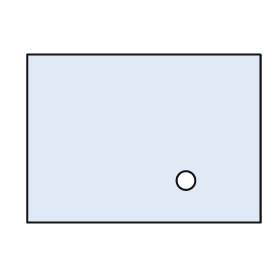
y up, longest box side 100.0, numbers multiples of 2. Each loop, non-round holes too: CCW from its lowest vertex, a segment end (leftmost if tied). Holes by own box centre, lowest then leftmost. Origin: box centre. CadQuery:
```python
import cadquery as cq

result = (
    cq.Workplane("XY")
    .moveTo(-50.0, -36.0)
    .lineTo(50.0, -36.0)
    .lineTo(50.0, 36.0)
    .lineTo(-50.0, 36.0)
    .close()
    .moveTo(18.0, -18.0)
    .circle(4.0)
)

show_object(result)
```